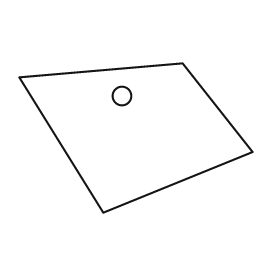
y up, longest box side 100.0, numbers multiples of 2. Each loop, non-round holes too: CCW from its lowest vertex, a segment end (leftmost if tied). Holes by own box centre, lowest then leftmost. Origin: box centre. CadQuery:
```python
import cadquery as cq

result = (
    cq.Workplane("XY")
    .moveTo(-14.0, -32.0)
    .lineTo(50.0, -6.0)
    .lineTo(20.0, 32.0)
    .lineTo(-50.0, 26.0)
    .close()
    .moveTo(-6.0, 18.0)
    .circle(4.0)
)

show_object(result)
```